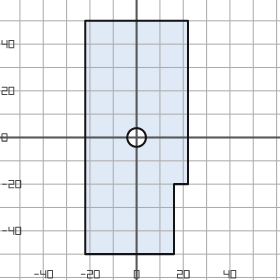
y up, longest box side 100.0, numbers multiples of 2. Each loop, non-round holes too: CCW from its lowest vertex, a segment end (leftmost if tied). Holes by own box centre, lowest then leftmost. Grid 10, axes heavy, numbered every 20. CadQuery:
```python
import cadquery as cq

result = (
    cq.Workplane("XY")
    .moveTo(-22.0, -50.0)
    .lineTo(16.0, -50.0)
    .lineTo(16.0, -20.0)
    .lineTo(22.0, -20.0)
    .lineTo(22.0, 50.0)
    .lineTo(-22.0, 50.0)
    .close()
    .moveTo(0.0, 0.0)
    .circle(4.0)
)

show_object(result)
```